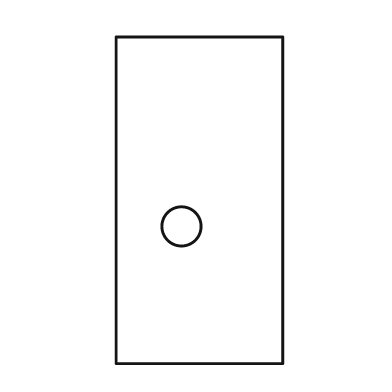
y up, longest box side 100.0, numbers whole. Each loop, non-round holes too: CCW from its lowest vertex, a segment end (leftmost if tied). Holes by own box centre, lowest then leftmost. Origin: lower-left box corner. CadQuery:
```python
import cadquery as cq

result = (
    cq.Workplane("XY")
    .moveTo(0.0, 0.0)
    .lineTo(51.0, 0.0)
    .lineTo(51.0, 100.0)
    .lineTo(0.0, 100.0)
    .close()
    .moveTo(20.0, 42.0)
    .circle(6.0)
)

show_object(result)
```